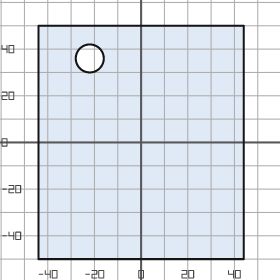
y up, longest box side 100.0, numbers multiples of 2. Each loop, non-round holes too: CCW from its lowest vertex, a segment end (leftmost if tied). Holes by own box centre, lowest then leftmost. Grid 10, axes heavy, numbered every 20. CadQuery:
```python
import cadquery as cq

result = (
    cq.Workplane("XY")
    .moveTo(-44.0, -50.0)
    .lineTo(44.0, -50.0)
    .lineTo(44.0, 50.0)
    .lineTo(-44.0, 50.0)
    .close()
    .moveTo(-22.0, 36.0)
    .circle(6.0)
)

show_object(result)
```